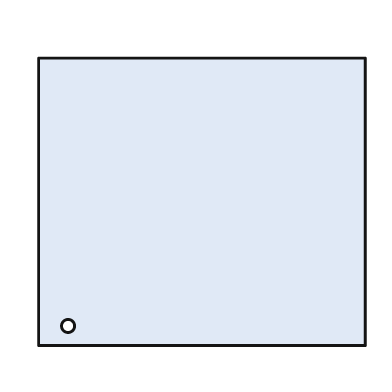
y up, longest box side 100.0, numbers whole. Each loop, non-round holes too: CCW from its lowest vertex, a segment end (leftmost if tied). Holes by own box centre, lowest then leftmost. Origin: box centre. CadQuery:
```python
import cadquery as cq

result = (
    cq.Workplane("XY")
    .moveTo(-50.0, -44.0)
    .lineTo(50.0, -44.0)
    .lineTo(50.0, 44.0)
    .lineTo(-50.0, 44.0)
    .close()
    .moveTo(-41.0, -38.0)
    .circle(2.0)
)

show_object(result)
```